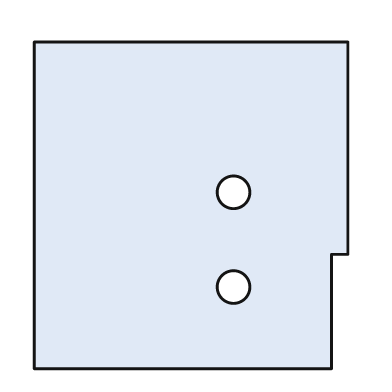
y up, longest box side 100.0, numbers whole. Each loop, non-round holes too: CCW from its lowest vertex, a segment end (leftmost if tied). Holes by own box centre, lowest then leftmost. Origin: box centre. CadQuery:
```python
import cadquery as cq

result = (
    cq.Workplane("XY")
    .moveTo(-48.0, -50.0)
    .lineTo(43.0, -50.0)
    .lineTo(43.0, -15.0)
    .lineTo(48.0, -15.0)
    .lineTo(48.0, 50.0)
    .lineTo(-48.0, 50.0)
    .close()
    .moveTo(13.0, -25.0)
    .circle(5.0)
    .moveTo(13.0, 4.0)
    .circle(5.0)
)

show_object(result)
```